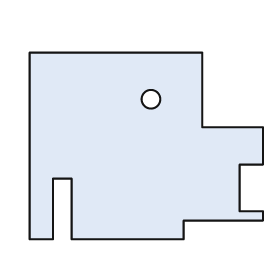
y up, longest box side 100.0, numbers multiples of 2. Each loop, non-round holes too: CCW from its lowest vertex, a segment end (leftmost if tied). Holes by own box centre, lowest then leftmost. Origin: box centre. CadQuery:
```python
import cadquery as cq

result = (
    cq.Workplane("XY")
    .moveTo(-50.0, -40.0)
    .lineTo(-40.0, -40.0)
    .lineTo(-40.0, -14.0)
    .lineTo(-32.0, -14.0)
    .lineTo(-32.0, -40.0)
    .lineTo(16.0, -40.0)
    .lineTo(16.0, -32.0)
    .lineTo(50.0, -32.0)
    .lineTo(50.0, -28.0)
    .lineTo(40.0, -28.0)
    .lineTo(40.0, -8.0)
    .lineTo(50.0, -8.0)
    .lineTo(50.0, 8.0)
    .lineTo(24.0, 8.0)
    .lineTo(24.0, 40.0)
    .lineTo(-50.0, 40.0)
    .close()
    .moveTo(2.0, 20.0)
    .circle(4.0)
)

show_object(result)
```